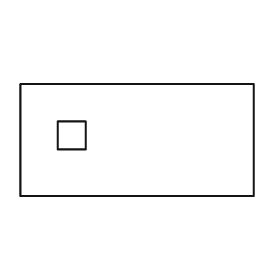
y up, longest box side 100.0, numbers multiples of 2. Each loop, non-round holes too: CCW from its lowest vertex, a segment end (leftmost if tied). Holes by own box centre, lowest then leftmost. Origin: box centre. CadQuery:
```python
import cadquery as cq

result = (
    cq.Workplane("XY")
    .moveTo(-50.0, -24.0)
    .lineTo(50.0, -24.0)
    .lineTo(50.0, 24.0)
    .lineTo(-50.0, 24.0)
    .close()
    .moveTo(-34.0, -4.0)
    .lineTo(-22.0, -4.0)
    .lineTo(-22.0, 8.0)
    .lineTo(-34.0, 8.0)
    .close()
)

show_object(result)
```